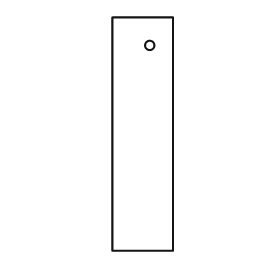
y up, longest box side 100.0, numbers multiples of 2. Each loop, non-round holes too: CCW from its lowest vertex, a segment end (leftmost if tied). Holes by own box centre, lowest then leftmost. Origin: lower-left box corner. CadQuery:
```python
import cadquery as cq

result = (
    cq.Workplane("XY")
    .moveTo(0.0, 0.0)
    .lineTo(26.0, 0.0)
    .lineTo(26.0, 100.0)
    .lineTo(0.0, 100.0)
    .close()
    .moveTo(16.0, 88.0)
    .circle(2.0)
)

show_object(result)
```